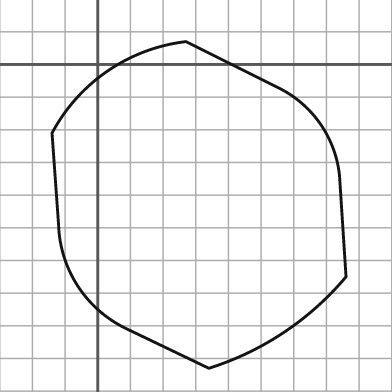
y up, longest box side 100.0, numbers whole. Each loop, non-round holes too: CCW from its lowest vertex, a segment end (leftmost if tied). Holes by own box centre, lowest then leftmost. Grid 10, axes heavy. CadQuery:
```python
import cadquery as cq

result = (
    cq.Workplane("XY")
    .moveTo(34.0, -93.0)
    .threePointArc((57.0, -82.0), (76.0, -65.0))
    .lineTo(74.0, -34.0)
    .threePointArc((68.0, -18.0), (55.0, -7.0))
    .lineTo(27.0, 7.0)
    .threePointArc((3.0, -2.0), (-14.0, -21.0))
    .lineTo(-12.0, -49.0)
    .threePointArc((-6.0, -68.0), (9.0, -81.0))
    .close()
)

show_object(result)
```